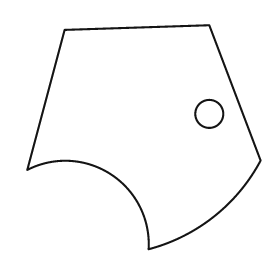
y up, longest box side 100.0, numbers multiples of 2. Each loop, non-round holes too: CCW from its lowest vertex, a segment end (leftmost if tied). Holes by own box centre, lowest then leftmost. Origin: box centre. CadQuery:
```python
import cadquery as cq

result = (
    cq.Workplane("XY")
    .moveTo(2.0, -48.0)
    .threePointArc((30.0, -34.0), (50.0, -10.0))
    .lineTo(28.0, 48.0)
    .lineTo(-34.0, 46.0)
    .lineTo(-50.0, -14.0)
    .threePointArc((-14.0, -16.0), (2.0, -48.0))
    .close()
    .moveTo(28.0, 10.0)
    .circle(6.0)
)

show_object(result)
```